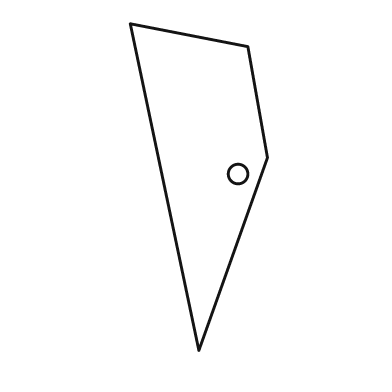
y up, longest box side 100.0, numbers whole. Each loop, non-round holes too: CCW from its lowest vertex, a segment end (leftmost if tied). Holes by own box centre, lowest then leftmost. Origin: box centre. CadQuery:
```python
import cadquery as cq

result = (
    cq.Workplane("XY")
    .moveTo(0.0, -50.0)
    .lineTo(21.0, 9.0)
    .lineTo(15.0, 43.0)
    .lineTo(-21.0, 50.0)
    .close()
    .moveTo(12.0, 4.0)
    .circle(3.0)
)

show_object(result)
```